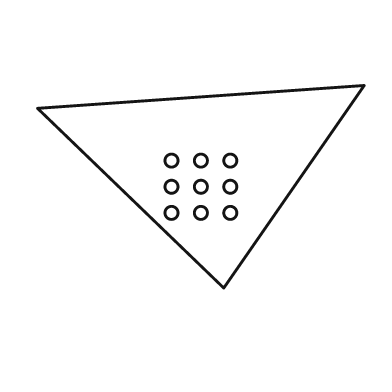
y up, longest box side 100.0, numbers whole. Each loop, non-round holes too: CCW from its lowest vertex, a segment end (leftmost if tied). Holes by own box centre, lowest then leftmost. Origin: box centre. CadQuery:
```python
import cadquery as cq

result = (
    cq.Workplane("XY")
    .moveTo(7.0, -31.0)
    .lineTo(50.0, 31.0)
    .lineTo(-50.0, 24.0)
    .close()
    .moveTo(-9.0, -8.0)
    .circle(2.0)
    .moveTo(0.0, -8.0)
    .circle(2.0)
    .moveTo(9.0, -8.0)
    .circle(2.0)
    .moveTo(-9.0, 0.0)
    .circle(2.0)
    .moveTo(0.0, 0.0)
    .circle(2.0)
    .moveTo(9.0, 0.0)
    .circle(2.0)
    .moveTo(-9.0, 8.0)
    .circle(2.0)
    .moveTo(0.0, 8.0)
    .circle(2.0)
    .moveTo(9.0, 8.0)
    .circle(2.0)
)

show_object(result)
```